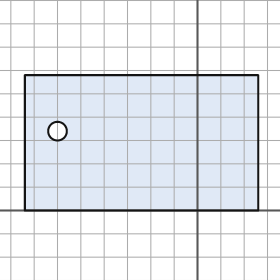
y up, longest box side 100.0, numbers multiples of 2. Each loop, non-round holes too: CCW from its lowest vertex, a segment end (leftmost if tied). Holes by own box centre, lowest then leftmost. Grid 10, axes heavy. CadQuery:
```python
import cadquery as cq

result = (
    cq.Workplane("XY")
    .moveTo(-74.0, 0.0)
    .lineTo(26.0, 0.0)
    .lineTo(26.0, 58.0)
    .lineTo(-74.0, 58.0)
    .close()
    .moveTo(-60.0, 34.0)
    .circle(4.0)
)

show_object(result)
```